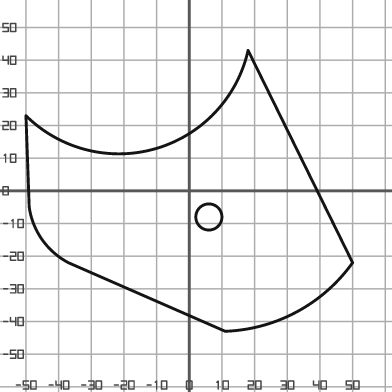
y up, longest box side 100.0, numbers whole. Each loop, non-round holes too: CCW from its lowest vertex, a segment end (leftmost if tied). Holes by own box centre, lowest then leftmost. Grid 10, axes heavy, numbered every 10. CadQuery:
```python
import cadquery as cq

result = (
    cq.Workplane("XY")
    .moveTo(11.0, -43.0)
    .threePointArc((33.0, -37.0), (50.0, -22.0))
    .lineTo(18.0, 43.0)
    .threePointArc((-10.0, 13.0), (-50.0, 23.0))
    .lineTo(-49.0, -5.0)
    .threePointArc((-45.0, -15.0), (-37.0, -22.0))
    .close()
    .moveTo(6.0, -8.0)
    .circle(4.0)
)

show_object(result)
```